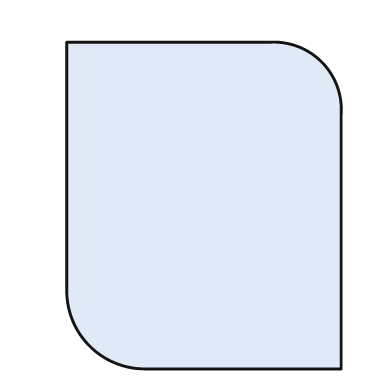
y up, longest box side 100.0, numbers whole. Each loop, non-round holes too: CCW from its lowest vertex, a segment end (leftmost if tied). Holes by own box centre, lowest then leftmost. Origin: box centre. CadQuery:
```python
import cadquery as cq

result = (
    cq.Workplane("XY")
    .moveTo(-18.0, -50.0)
    .lineTo(42.0, -50.0)
    .lineTo(42.0, 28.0)
    .threePointArc((36.0, 44.0), (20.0, 50.0))
    .lineTo(-42.0, 50.0)
    .lineTo(-42.0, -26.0)
    .threePointArc((-35.0, -43.0), (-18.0, -50.0))
    .close()
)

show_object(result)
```